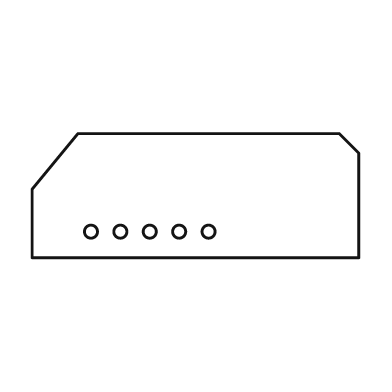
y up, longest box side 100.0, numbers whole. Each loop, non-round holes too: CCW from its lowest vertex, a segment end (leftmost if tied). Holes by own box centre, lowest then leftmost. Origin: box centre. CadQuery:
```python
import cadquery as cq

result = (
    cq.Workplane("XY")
    .moveTo(-50.0, -19.0)
    .lineTo(50.0, -19.0)
    .lineTo(50.0, 13.0)
    .lineTo(44.0, 19.0)
    .lineTo(-36.0, 19.0)
    .lineTo(-50.0, 2.0)
    .close()
    .moveTo(-32.0, -11.0)
    .circle(2.0)
    .moveTo(-23.0, -11.0)
    .circle(2.0)
    .moveTo(-14.0, -11.0)
    .circle(2.0)
    .moveTo(-5.0, -11.0)
    .circle(2.0)
    .moveTo(4.0, -11.0)
    .circle(2.0)
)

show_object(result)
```